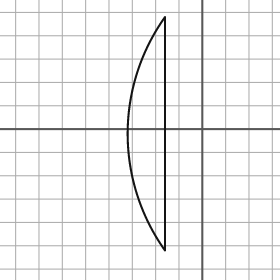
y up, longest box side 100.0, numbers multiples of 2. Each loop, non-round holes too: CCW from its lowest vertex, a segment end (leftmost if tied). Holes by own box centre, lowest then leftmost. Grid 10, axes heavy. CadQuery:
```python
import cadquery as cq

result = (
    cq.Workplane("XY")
    .moveTo(-16.0, -52.0)
    .lineTo(-16.0, 48.0)
    .threePointArc((-32.0, -2.0), (-16.0, -52.0))
    .close()
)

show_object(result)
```